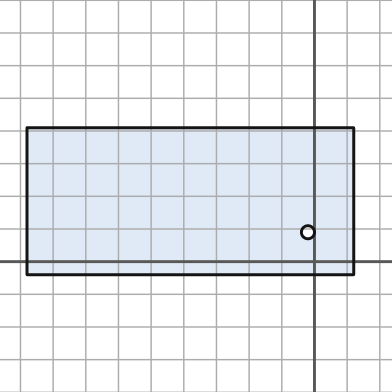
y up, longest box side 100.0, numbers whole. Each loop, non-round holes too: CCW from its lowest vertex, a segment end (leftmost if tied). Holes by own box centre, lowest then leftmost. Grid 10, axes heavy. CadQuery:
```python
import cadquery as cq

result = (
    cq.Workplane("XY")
    .moveTo(-88.0, -4.0)
    .lineTo(12.0, -4.0)
    .lineTo(12.0, 41.0)
    .lineTo(-88.0, 41.0)
    .close()
    .moveTo(-2.0, 9.0)
    .circle(2.0)
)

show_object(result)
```